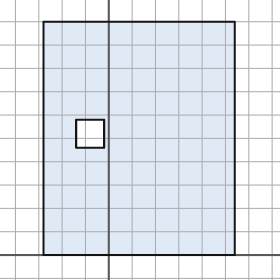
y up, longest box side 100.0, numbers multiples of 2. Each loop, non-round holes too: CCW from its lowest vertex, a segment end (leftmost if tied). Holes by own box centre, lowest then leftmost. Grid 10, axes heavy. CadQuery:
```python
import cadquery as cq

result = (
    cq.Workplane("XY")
    .moveTo(-28.0, 0.0)
    .lineTo(54.0, 0.0)
    .lineTo(54.0, 100.0)
    .lineTo(-28.0, 100.0)
    .close()
    .moveTo(-14.0, 46.0)
    .lineTo(-2.0, 46.0)
    .lineTo(-2.0, 58.0)
    .lineTo(-14.0, 58.0)
    .close()
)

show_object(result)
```